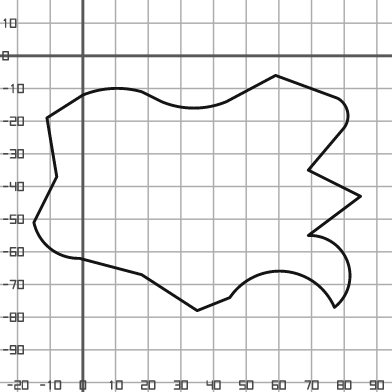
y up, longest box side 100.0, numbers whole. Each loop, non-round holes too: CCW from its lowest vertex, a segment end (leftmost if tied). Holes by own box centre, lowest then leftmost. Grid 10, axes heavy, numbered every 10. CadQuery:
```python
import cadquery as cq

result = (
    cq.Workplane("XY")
    .moveTo(35.0, -78.0)
    .lineTo(45.0, -74.0)
    .threePointArc((62.0, -66.0), (77.0, -77.0))
    .threePointArc((81.0, -63.0), (69.0, -55.0))
    .lineTo(85.0, -43.0)
    .lineTo(69.0, -35.0)
    .lineTo(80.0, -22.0)
    .threePointArc((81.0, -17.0), (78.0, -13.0))
    .lineTo(59.0, -6.0)
    .lineTo(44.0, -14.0)
    .threePointArc((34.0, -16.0), (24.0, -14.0))
    .lineTo(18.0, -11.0)
    .threePointArc((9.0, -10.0), (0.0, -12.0))
    .lineTo(-11.0, -19.0)
    .lineTo(-8.0, -37.0)
    .lineTo(-15.0, -51.0)
    .threePointArc((-10.0, -59.0), (-1.0, -62.0))
    .lineTo(18.0, -67.0)
    .close()
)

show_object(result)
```